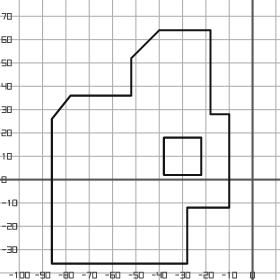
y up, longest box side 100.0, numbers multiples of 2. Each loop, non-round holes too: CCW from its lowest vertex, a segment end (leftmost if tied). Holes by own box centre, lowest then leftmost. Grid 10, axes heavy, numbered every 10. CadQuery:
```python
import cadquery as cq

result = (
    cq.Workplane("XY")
    .moveTo(-86.0, -36.0)
    .lineTo(-28.0, -36.0)
    .lineTo(-28.0, -12.0)
    .lineTo(-10.0, -12.0)
    .lineTo(-10.0, 28.0)
    .lineTo(-18.0, 28.0)
    .lineTo(-18.0, 64.0)
    .lineTo(-40.0, 64.0)
    .lineTo(-52.0, 52.0)
    .lineTo(-52.0, 36.0)
    .lineTo(-78.0, 36.0)
    .lineTo(-86.0, 26.0)
    .close()
    .moveTo(-38.0, 2.0)
    .lineTo(-22.0, 2.0)
    .lineTo(-22.0, 18.0)
    .lineTo(-38.0, 18.0)
    .close()
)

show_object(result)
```